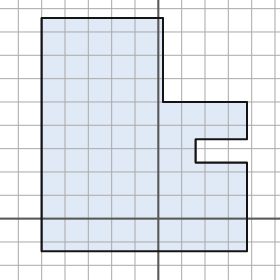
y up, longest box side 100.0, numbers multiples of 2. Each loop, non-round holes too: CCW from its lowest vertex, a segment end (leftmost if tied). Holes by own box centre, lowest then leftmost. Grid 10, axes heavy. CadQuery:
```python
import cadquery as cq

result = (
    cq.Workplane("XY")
    .moveTo(-50.0, -14.0)
    .lineTo(38.0, -14.0)
    .lineTo(38.0, 24.0)
    .lineTo(16.0, 24.0)
    .lineTo(16.0, 34.0)
    .lineTo(38.0, 34.0)
    .lineTo(38.0, 50.0)
    .lineTo(2.0, 50.0)
    .lineTo(2.0, 86.0)
    .lineTo(-50.0, 86.0)
    .close()
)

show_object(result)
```